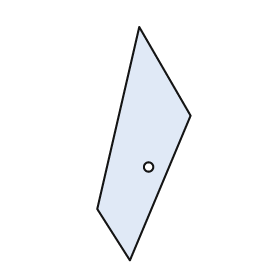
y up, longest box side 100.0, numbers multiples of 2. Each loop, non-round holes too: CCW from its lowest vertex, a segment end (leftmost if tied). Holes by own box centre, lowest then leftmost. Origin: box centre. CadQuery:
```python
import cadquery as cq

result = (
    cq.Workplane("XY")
    .moveTo(-6.0, -50.0)
    .lineTo(20.0, 12.0)
    .lineTo(-2.0, 50.0)
    .lineTo(-20.0, -28.0)
    .close()
    .moveTo(2.0, -10.0)
    .circle(2.0)
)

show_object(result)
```